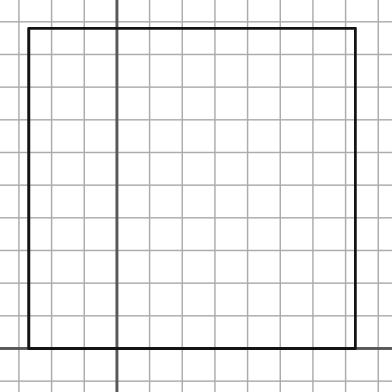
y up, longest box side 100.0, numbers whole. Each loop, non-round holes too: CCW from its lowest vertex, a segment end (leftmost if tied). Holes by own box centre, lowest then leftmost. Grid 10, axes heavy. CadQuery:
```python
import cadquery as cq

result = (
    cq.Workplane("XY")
    .moveTo(-27.0, 0.0)
    .lineTo(73.0, 0.0)
    .lineTo(73.0, 98.0)
    .lineTo(-27.0, 98.0)
    .close()
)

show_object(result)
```